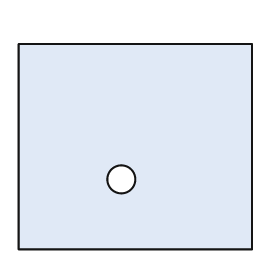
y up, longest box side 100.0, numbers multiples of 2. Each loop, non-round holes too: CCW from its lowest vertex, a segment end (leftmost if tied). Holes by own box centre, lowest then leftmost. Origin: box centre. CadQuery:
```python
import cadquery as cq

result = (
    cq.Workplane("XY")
    .moveTo(-50.0, -44.0)
    .lineTo(50.0, -44.0)
    .lineTo(50.0, 44.0)
    .lineTo(-50.0, 44.0)
    .close()
    .moveTo(-6.0, -14.0)
    .circle(6.0)
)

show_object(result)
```